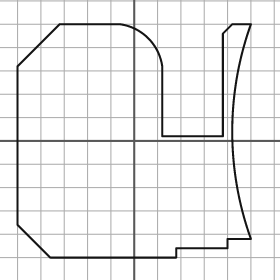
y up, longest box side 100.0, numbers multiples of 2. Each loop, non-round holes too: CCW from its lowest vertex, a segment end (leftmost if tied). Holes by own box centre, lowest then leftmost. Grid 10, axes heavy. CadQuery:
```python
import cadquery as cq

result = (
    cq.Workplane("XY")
    .moveTo(-36.0, -50.0)
    .lineTo(18.0, -50.0)
    .lineTo(18.0, -46.0)
    .lineTo(40.0, -46.0)
    .lineTo(40.0, -42.0)
    .lineTo(50.0, -42.0)
    .threePointArc((42.0, 4.0), (50.0, 50.0))
    .lineTo(42.0, 50.0)
    .lineTo(38.0, 46.0)
    .lineTo(38.0, 2.0)
    .lineTo(12.0, 2.0)
    .lineTo(12.0, 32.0)
    .threePointArc((6.0, 44.0), (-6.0, 50.0))
    .lineTo(-32.0, 50.0)
    .lineTo(-50.0, 32.0)
    .lineTo(-50.0, -36.0)
    .close()
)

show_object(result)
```